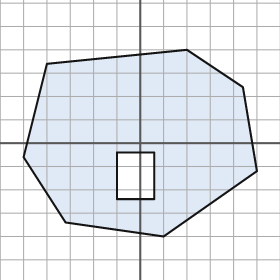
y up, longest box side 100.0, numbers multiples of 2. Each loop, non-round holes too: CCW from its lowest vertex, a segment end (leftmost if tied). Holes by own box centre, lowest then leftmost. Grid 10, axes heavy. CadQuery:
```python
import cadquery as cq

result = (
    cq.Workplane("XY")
    .moveTo(10.0, -40.0)
    .lineTo(50.0, -12.0)
    .lineTo(44.0, 24.0)
    .lineTo(20.0, 40.0)
    .lineTo(-40.0, 34.0)
    .lineTo(-50.0, -6.0)
    .lineTo(-32.0, -34.0)
    .close()
    .moveTo(-10.0, -24.0)
    .lineTo(6.0, -24.0)
    .lineTo(6.0, -4.0)
    .lineTo(-10.0, -4.0)
    .close()
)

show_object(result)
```